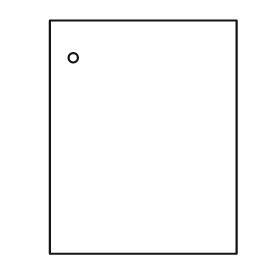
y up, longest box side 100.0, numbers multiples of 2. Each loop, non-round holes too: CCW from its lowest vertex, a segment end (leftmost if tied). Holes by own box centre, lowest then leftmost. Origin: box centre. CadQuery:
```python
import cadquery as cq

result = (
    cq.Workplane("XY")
    .moveTo(-40.0, -50.0)
    .lineTo(40.0, -50.0)
    .lineTo(40.0, 50.0)
    .lineTo(-40.0, 50.0)
    .close()
    .moveTo(-30.0, 34.0)
    .circle(2.0)
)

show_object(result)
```